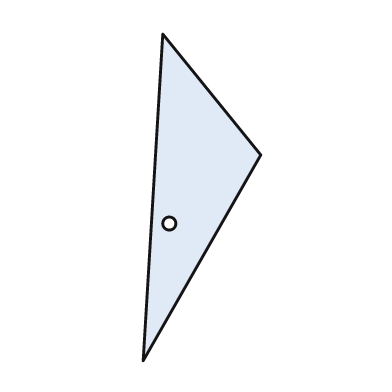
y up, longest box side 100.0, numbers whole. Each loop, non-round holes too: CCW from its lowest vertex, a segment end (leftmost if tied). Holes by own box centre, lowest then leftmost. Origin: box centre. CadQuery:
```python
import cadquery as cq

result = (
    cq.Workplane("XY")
    .moveTo(-18.0, -50.0)
    .lineTo(18.0, 13.0)
    .lineTo(-12.0, 50.0)
    .close()
    .moveTo(-10.0, -8.0)
    .circle(2.0)
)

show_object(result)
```